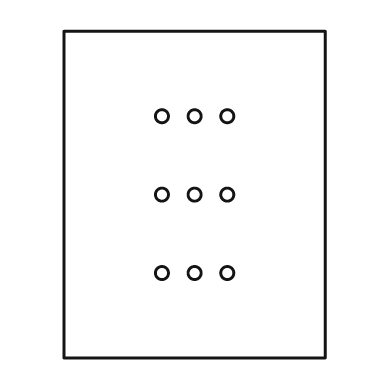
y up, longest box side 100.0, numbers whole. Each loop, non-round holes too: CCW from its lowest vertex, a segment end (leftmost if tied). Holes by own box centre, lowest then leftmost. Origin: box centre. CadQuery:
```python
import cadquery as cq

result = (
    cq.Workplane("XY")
    .moveTo(-40.0, -50.0)
    .lineTo(40.0, -50.0)
    .lineTo(40.0, 50.0)
    .lineTo(-40.0, 50.0)
    .close()
    .moveTo(-10.0, -24.0)
    .circle(2.0)
    .moveTo(0.0, -24.0)
    .circle(2.0)
    .moveTo(10.0, -24.0)
    .circle(2.0)
    .moveTo(-10.0, 0.0)
    .circle(2.0)
    .moveTo(0.0, 0.0)
    .circle(2.0)
    .moveTo(10.0, 0.0)
    .circle(2.0)
    .moveTo(-10.0, 24.0)
    .circle(2.0)
    .moveTo(0.0, 24.0)
    .circle(2.0)
    .moveTo(10.0, 24.0)
    .circle(2.0)
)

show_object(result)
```